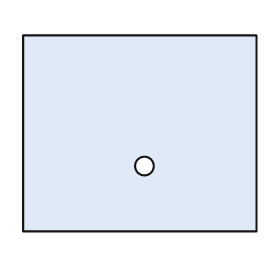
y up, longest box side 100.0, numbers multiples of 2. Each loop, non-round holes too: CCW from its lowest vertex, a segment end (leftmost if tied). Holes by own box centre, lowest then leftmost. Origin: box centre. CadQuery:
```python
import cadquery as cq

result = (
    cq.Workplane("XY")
    .moveTo(-50.0, -42.0)
    .lineTo(50.0, -42.0)
    .lineTo(50.0, 42.0)
    .lineTo(-50.0, 42.0)
    .close()
    .moveTo(2.0, -14.0)
    .circle(4.0)
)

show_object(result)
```